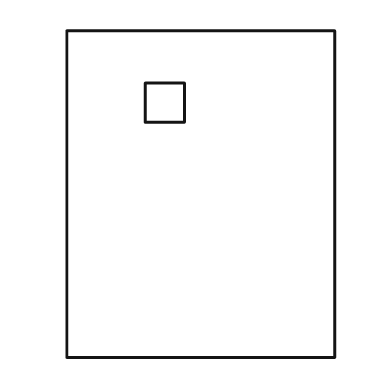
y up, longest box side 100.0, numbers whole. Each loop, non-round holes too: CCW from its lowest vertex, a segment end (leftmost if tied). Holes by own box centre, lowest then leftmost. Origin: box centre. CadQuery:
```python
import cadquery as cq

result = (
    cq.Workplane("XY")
    .moveTo(-41.0, -50.0)
    .lineTo(41.0, -50.0)
    .lineTo(41.0, 50.0)
    .lineTo(-41.0, 50.0)
    .close()
    .moveTo(-17.0, 22.0)
    .lineTo(-5.0, 22.0)
    .lineTo(-5.0, 34.0)
    .lineTo(-17.0, 34.0)
    .close()
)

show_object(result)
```